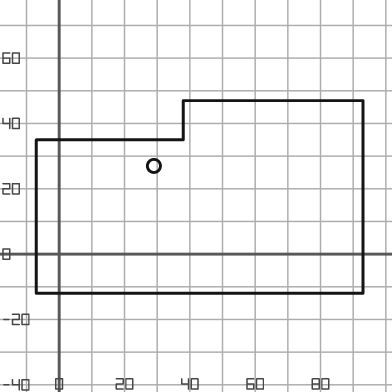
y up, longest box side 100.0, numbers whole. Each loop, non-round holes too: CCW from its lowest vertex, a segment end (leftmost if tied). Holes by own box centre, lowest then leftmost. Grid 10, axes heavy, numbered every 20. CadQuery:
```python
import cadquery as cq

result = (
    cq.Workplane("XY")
    .moveTo(-7.0, -12.0)
    .lineTo(93.0, -12.0)
    .lineTo(93.0, 47.0)
    .lineTo(38.0, 47.0)
    .lineTo(38.0, 35.0)
    .lineTo(-7.0, 35.0)
    .close()
    .moveTo(29.0, 27.0)
    .circle(2.0)
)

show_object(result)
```